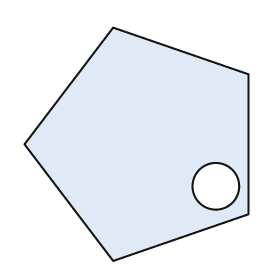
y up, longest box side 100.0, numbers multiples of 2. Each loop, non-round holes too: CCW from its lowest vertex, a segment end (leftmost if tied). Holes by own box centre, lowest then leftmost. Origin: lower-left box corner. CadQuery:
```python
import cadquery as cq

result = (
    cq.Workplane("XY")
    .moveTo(38.0, 0.0)
    .lineTo(96.0, 20.0)
    .lineTo(96.0, 80.0)
    .lineTo(38.0, 100.0)
    .lineTo(0.0, 50.0)
    .close()
    .moveTo(82.0, 32.0)
    .circle(10.0)
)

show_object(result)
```